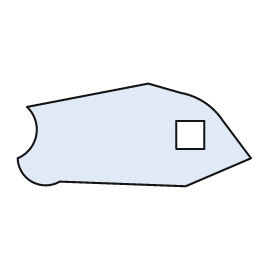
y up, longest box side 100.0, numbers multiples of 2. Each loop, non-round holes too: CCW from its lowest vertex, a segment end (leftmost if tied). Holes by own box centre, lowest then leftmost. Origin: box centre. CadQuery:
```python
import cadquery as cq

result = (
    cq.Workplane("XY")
    .moveTo(22.0, -22.0)
    .lineTo(50.0, -10.0)
    .lineTo(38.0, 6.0)
    .threePointArc((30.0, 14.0), (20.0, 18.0))
    .lineTo(6.0, 22.0)
    .lineTo(-46.0, 12.0)
    .threePointArc((-42.0, 0.0), (-50.0, -10.0))
    .threePointArc((-44.0, -20.0), (-32.0, -20.0))
    .close()
    .moveTo(18.0, -6.0)
    .lineTo(30.0, -6.0)
    .lineTo(30.0, 6.0)
    .lineTo(18.0, 6.0)
    .close()
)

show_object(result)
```